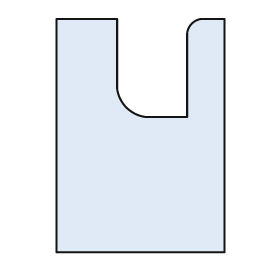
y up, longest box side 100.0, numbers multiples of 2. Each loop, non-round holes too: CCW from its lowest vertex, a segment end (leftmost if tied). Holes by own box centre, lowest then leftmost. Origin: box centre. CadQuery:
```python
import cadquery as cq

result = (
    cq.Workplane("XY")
    .moveTo(-36.0, -50.0)
    .lineTo(36.0, -50.0)
    .lineTo(36.0, 50.0)
    .lineTo(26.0, 50.0)
    .threePointArc((22.0, 48.0), (20.0, 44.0))
    .lineTo(20.0, 8.0)
    .lineTo(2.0, 8.0)
    .threePointArc((-6.0, 12.0), (-10.0, 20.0))
    .lineTo(-10.0, 50.0)
    .lineTo(-36.0, 50.0)
    .close()
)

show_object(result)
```